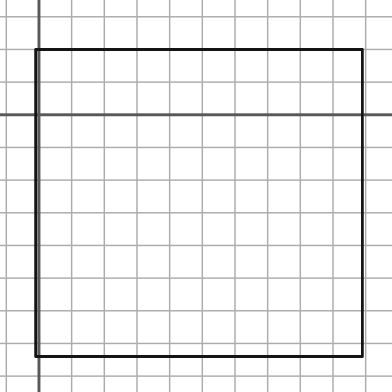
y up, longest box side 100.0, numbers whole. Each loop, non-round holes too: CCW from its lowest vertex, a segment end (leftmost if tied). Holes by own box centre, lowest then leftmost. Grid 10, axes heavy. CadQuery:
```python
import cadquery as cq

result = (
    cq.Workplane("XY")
    .moveTo(-1.0, -74.0)
    .lineTo(99.0, -74.0)
    .lineTo(99.0, 20.0)
    .lineTo(-1.0, 20.0)
    .close()
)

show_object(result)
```